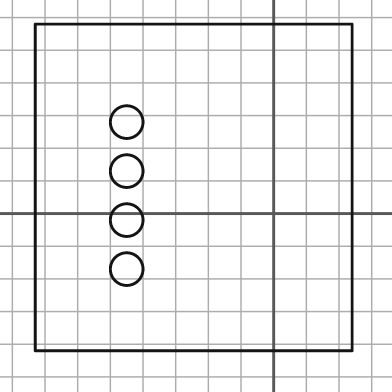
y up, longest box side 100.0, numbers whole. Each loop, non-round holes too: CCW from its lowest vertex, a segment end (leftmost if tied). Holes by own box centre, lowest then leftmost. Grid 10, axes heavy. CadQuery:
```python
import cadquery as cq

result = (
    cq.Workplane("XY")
    .moveTo(-73.0, -42.0)
    .lineTo(24.0, -42.0)
    .lineTo(24.0, 58.0)
    .lineTo(-73.0, 58.0)
    .close()
    .moveTo(-45.0, -17.0)
    .circle(5.0)
    .moveTo(-45.0, -2.0)
    .circle(5.0)
    .moveTo(-45.0, 13.0)
    .circle(5.0)
    .moveTo(-45.0, 28.0)
    .circle(5.0)
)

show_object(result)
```